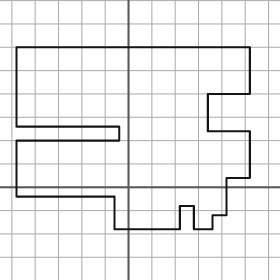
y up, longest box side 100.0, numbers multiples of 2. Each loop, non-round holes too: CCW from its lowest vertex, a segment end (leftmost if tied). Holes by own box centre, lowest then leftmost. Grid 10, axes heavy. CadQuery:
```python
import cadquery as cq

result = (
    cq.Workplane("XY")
    .moveTo(-6.0, -18.0)
    .lineTo(22.0, -18.0)
    .lineTo(22.0, -8.0)
    .lineTo(28.0, -8.0)
    .lineTo(28.0, -18.0)
    .lineTo(36.0, -18.0)
    .lineTo(36.0, -12.0)
    .lineTo(42.0, -12.0)
    .lineTo(42.0, 4.0)
    .lineTo(52.0, 4.0)
    .lineTo(52.0, 24.0)
    .lineTo(34.0, 24.0)
    .lineTo(34.0, 40.0)
    .lineTo(52.0, 40.0)
    .lineTo(52.0, 60.0)
    .lineTo(-48.0, 60.0)
    .lineTo(-48.0, 26.0)
    .lineTo(-4.0, 26.0)
    .lineTo(-4.0, 20.0)
    .lineTo(-48.0, 20.0)
    .lineTo(-48.0, -4.0)
    .lineTo(-6.0, -4.0)
    .close()
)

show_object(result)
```